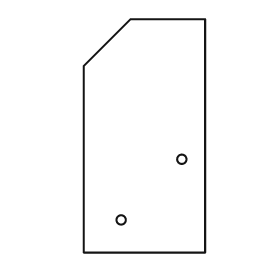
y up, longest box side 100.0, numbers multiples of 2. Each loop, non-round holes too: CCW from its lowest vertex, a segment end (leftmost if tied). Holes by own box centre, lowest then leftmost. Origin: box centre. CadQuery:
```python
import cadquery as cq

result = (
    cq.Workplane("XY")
    .moveTo(-26.0, -50.0)
    .lineTo(26.0, -50.0)
    .lineTo(26.0, 50.0)
    .lineTo(-6.0, 50.0)
    .lineTo(-26.0, 30.0)
    .close()
    .moveTo(-10.0, -36.0)
    .circle(2.0)
    .moveTo(16.0, -10.0)
    .circle(2.0)
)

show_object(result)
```